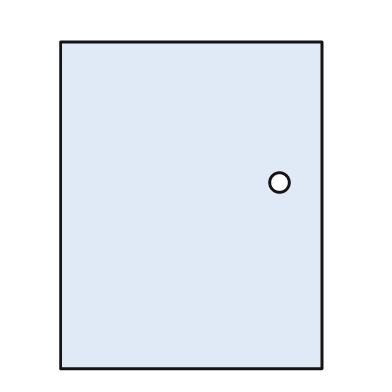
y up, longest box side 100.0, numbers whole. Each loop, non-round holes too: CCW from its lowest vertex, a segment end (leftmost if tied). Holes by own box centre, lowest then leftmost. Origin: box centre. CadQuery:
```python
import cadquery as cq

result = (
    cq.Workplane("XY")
    .moveTo(-40.0, -50.0)
    .lineTo(40.0, -50.0)
    .lineTo(40.0, 50.0)
    .lineTo(-40.0, 50.0)
    .close()
    .moveTo(27.0, 7.0)
    .circle(3.0)
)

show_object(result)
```